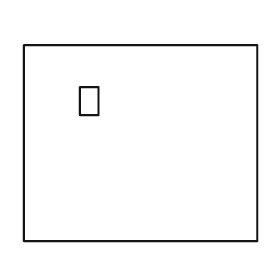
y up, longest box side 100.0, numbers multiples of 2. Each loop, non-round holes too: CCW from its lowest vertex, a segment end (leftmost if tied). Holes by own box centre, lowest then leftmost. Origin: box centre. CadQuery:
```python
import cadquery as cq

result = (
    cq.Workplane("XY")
    .moveTo(-50.0, -42.0)
    .lineTo(50.0, -42.0)
    .lineTo(50.0, 42.0)
    .lineTo(-50.0, 42.0)
    .close()
    .moveTo(-26.0, 12.0)
    .lineTo(-18.0, 12.0)
    .lineTo(-18.0, 24.0)
    .lineTo(-26.0, 24.0)
    .close()
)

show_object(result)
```